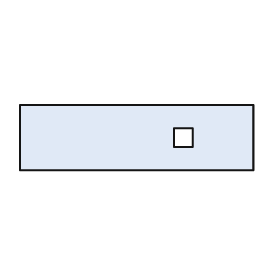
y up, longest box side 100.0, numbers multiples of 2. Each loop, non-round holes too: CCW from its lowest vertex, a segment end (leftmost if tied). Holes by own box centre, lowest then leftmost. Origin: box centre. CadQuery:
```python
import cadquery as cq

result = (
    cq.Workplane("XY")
    .moveTo(-50.0, -14.0)
    .lineTo(50.0, -14.0)
    .lineTo(50.0, 14.0)
    .lineTo(-50.0, 14.0)
    .close()
    .moveTo(16.0, -4.0)
    .lineTo(24.0, -4.0)
    .lineTo(24.0, 4.0)
    .lineTo(16.0, 4.0)
    .close()
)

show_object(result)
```